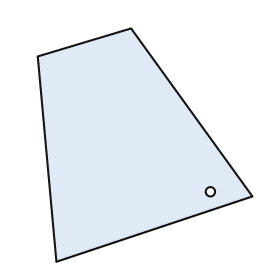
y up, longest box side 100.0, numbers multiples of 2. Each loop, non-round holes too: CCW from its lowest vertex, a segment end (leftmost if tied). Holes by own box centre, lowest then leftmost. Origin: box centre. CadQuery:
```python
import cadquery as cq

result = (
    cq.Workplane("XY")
    .moveTo(-38.0, -50.0)
    .lineTo(46.0, -22.0)
    .lineTo(-6.0, 50.0)
    .lineTo(-46.0, 38.0)
    .close()
    .moveTo(28.0, -20.0)
    .circle(2.0)
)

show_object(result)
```